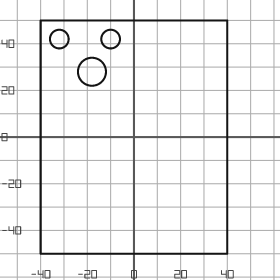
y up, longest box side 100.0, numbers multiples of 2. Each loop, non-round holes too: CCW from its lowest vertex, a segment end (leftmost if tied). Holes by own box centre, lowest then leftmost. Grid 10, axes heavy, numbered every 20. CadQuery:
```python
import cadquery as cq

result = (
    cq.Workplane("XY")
    .moveTo(-40.0, -50.0)
    .lineTo(40.0, -50.0)
    .lineTo(40.0, 50.0)
    .lineTo(-40.0, 50.0)
    .close()
    .moveTo(-18.0, 28.0)
    .circle(6.0)
    .moveTo(-32.0, 42.0)
    .circle(4.0)
    .moveTo(-10.0, 42.0)
    .circle(4.0)
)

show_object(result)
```